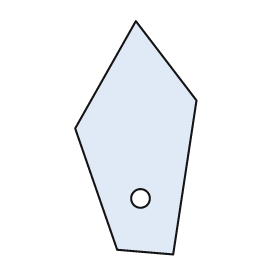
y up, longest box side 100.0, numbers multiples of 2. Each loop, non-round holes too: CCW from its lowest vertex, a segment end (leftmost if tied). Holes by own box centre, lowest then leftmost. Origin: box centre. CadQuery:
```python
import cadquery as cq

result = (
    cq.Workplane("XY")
    .moveTo(16.0, -50.0)
    .lineTo(26.0, 16.0)
    .lineTo(0.0, 50.0)
    .lineTo(-26.0, 4.0)
    .lineTo(-8.0, -48.0)
    .close()
    .moveTo(2.0, -26.0)
    .circle(4.0)
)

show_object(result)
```